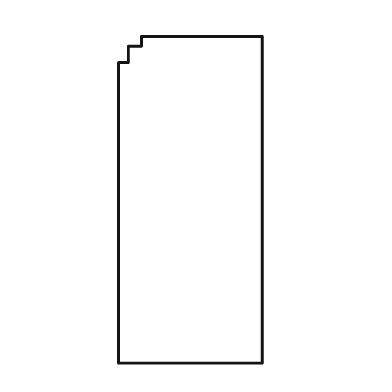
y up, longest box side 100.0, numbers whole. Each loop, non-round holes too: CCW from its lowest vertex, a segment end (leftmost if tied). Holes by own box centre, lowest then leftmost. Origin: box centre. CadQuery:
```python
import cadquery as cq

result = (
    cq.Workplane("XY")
    .moveTo(-22.0, -50.0)
    .lineTo(22.0, -50.0)
    .lineTo(22.0, 50.0)
    .lineTo(-15.0, 50.0)
    .lineTo(-15.0, 47.0)
    .lineTo(-19.0, 47.0)
    .lineTo(-19.0, 42.0)
    .lineTo(-22.0, 42.0)
    .close()
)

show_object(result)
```